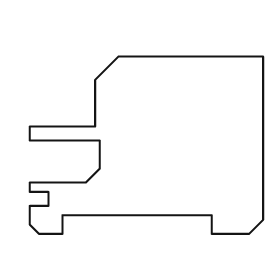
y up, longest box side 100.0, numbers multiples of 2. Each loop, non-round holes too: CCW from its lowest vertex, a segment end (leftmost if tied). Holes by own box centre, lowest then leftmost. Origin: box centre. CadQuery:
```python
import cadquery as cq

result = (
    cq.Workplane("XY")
    .moveTo(-46.0, -38.0)
    .lineTo(-36.0, -38.0)
    .lineTo(-36.0, -30.0)
    .lineTo(28.0, -30.0)
    .lineTo(28.0, -38.0)
    .lineTo(44.0, -38.0)
    .lineTo(50.0, -32.0)
    .lineTo(50.0, 38.0)
    .lineTo(-12.0, 38.0)
    .lineTo(-22.0, 28.0)
    .lineTo(-22.0, 8.0)
    .lineTo(-50.0, 8.0)
    .lineTo(-50.0, 2.0)
    .lineTo(-20.0, 2.0)
    .lineTo(-20.0, -10.0)
    .lineTo(-26.0, -16.0)
    .lineTo(-50.0, -16.0)
    .lineTo(-50.0, -20.0)
    .lineTo(-42.0, -20.0)
    .lineTo(-42.0, -26.0)
    .lineTo(-50.0, -26.0)
    .lineTo(-50.0, -34.0)
    .close()
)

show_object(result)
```